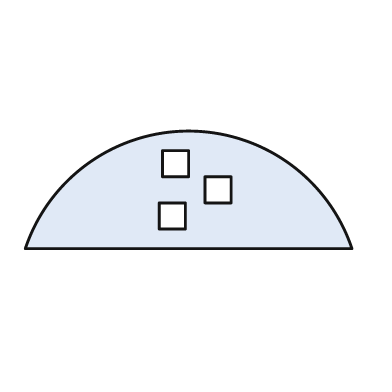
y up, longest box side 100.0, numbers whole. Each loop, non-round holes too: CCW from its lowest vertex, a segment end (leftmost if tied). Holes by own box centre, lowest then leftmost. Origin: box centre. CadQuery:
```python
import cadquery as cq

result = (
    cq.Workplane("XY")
    .moveTo(-50.0, -18.0)
    .lineTo(50.0, -18.0)
    .threePointArc((0.0, 18.0), (-50.0, -18.0))
    .close()
    .moveTo(-9.0, -12.0)
    .lineTo(-1.0, -12.0)
    .lineTo(-1.0, -4.0)
    .lineTo(-9.0, -4.0)
    .close()
    .moveTo(5.0, -4.0)
    .lineTo(13.0, -4.0)
    .lineTo(13.0, 4.0)
    .lineTo(5.0, 4.0)
    .close()
    .moveTo(-8.0, 4.0)
    .lineTo(0.0, 4.0)
    .lineTo(0.0, 12.0)
    .lineTo(-8.0, 12.0)
    .close()
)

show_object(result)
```